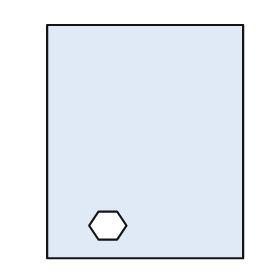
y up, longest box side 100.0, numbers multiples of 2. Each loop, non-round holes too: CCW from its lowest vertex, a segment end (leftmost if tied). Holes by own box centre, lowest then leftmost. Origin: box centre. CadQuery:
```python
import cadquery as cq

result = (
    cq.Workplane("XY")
    .moveTo(-42.0, -50.0)
    .lineTo(42.0, -50.0)
    .lineTo(42.0, 50.0)
    .lineTo(-42.0, 50.0)
    .close()
    .moveTo(-20.0, -42.0)
    .lineTo(-12.0, -42.0)
    .lineTo(-8.0, -36.0)
    .lineTo(-12.0, -30.0)
    .lineTo(-20.0, -30.0)
    .lineTo(-24.0, -36.0)
    .close()
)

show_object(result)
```